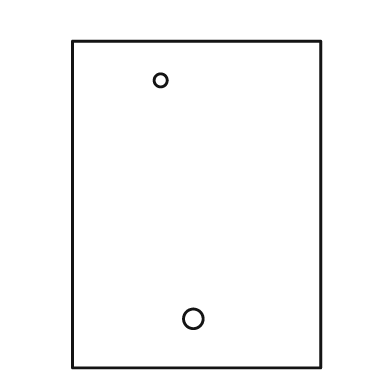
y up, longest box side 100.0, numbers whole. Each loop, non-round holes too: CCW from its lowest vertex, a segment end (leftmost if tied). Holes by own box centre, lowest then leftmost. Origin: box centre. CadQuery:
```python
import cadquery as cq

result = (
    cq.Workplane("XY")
    .moveTo(-38.0, -50.0)
    .lineTo(38.0, -50.0)
    .lineTo(38.0, 50.0)
    .lineTo(-38.0, 50.0)
    .close()
    .moveTo(-1.0, -35.0)
    .circle(3.0)
    .moveTo(-11.0, 38.0)
    .circle(2.0)
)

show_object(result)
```